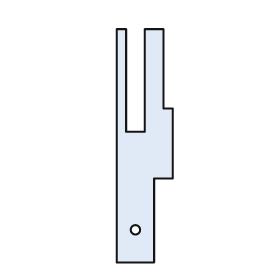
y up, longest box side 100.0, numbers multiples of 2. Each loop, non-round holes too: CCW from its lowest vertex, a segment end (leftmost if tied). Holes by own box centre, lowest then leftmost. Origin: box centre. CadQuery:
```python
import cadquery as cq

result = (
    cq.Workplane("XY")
    .moveTo(-12.0, -50.0)
    .lineTo(4.0, -50.0)
    .lineTo(4.0, -14.0)
    .lineTo(12.0, -14.0)
    .lineTo(12.0, 16.0)
    .lineTo(8.0, 16.0)
    .lineTo(8.0, 50.0)
    .lineTo(0.0, 50.0)
    .lineTo(0.0, 6.0)
    .lineTo(-8.0, 6.0)
    .lineTo(-8.0, 50.0)
    .lineTo(-12.0, 50.0)
    .close()
    .moveTo(-4.0, -36.0)
    .circle(2.0)
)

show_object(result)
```